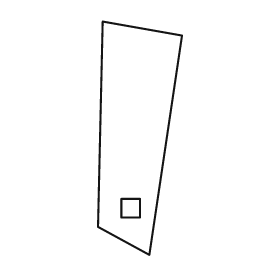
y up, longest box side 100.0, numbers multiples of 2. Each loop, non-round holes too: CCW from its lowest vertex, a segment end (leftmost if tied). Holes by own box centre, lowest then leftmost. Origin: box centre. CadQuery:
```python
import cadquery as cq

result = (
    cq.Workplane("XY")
    .moveTo(4.0, -50.0)
    .lineTo(18.0, 44.0)
    .lineTo(-16.0, 50.0)
    .lineTo(-18.0, -38.0)
    .close()
    .moveTo(-8.0, -34.0)
    .lineTo(0.0, -34.0)
    .lineTo(0.0, -26.0)
    .lineTo(-8.0, -26.0)
    .close()
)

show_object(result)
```